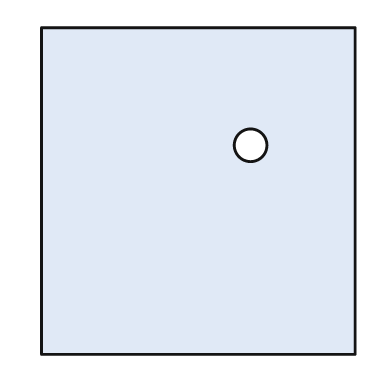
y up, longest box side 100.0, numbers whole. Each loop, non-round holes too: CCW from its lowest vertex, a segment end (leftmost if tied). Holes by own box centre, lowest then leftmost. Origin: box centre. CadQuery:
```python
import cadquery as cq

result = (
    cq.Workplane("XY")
    .moveTo(-48.0, -50.0)
    .lineTo(48.0, -50.0)
    .lineTo(48.0, 50.0)
    .lineTo(-48.0, 50.0)
    .close()
    .moveTo(16.0, 14.0)
    .circle(5.0)
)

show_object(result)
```